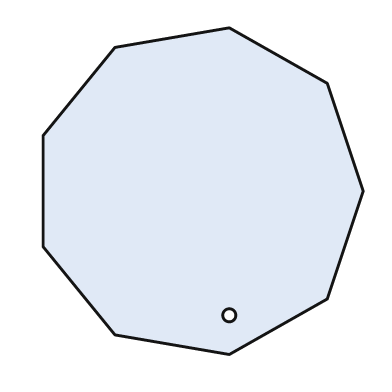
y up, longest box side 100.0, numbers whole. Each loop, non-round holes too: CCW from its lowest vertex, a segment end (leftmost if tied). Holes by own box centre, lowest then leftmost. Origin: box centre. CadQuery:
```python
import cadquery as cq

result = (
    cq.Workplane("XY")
    .moveTo(8.0, -50.0)
    .lineTo(38.0, -33.0)
    .lineTo(49.0, 0.0)
    .lineTo(38.0, 33.0)
    .lineTo(8.0, 50.0)
    .lineTo(-27.0, 44.0)
    .lineTo(-49.0, 17.0)
    .lineTo(-49.0, -17.0)
    .lineTo(-27.0, -44.0)
    .close()
    .moveTo(8.0, -38.0)
    .circle(2.0)
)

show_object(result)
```